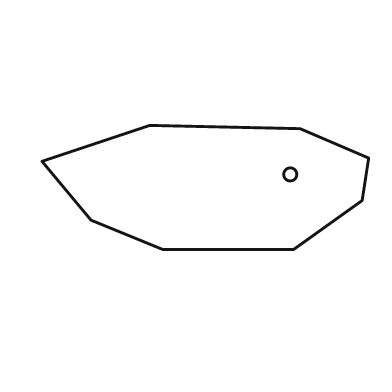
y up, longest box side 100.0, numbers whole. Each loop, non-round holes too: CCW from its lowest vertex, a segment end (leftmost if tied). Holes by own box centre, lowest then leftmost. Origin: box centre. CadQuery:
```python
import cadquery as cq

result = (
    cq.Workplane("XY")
    .moveTo(-13.0, -19.0)
    .lineTo(27.0, -19.0)
    .lineTo(48.0, -4.0)
    .lineTo(50.0, 9.0)
    .lineTo(29.0, 18.0)
    .lineTo(-17.0, 19.0)
    .lineTo(-50.0, 8.0)
    .lineTo(-35.0, -10.0)
    .close()
    .moveTo(26.0, 4.0)
    .circle(2.0)
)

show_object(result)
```